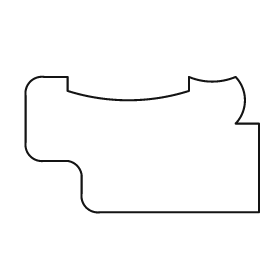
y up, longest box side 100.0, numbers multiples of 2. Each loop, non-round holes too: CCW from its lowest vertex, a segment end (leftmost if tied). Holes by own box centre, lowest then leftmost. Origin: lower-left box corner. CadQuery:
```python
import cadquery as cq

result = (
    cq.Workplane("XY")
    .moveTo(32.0, 0.0)
    .lineTo(100.0, 0.0)
    .lineTo(100.0, 38.0)
    .lineTo(90.0, 38.0)
    .threePointArc((94.0, 48.0), (90.0, 58.0))
    .threePointArc((80.0, 56.0), (70.0, 58.0))
    .lineTo(70.0, 52.0)
    .threePointArc((44.0, 48.0), (18.0, 52.0))
    .lineTo(18.0, 58.0)
    .lineTo(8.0, 58.0)
    .threePointArc((2.0, 56.0), (0.0, 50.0))
    .lineTo(0.0, 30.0)
    .threePointArc((2.0, 24.0), (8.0, 22.0))
    .lineTo(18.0, 22.0)
    .threePointArc((22.0, 20.0), (24.0, 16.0))
    .lineTo(24.0, 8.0)
    .threePointArc((26.0, 2.0), (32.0, 0.0))
    .close()
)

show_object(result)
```